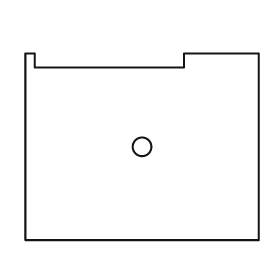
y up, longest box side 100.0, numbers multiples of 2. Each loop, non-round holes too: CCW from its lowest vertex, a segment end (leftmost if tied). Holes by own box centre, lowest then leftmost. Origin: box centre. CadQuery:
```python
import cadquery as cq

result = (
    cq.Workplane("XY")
    .moveTo(-50.0, -40.0)
    .lineTo(50.0, -40.0)
    .lineTo(50.0, 40.0)
    .lineTo(18.0, 40.0)
    .lineTo(18.0, 34.0)
    .lineTo(-46.0, 34.0)
    .lineTo(-46.0, 40.0)
    .lineTo(-50.0, 40.0)
    .close()
    .moveTo(0.0, 0.0)
    .circle(4.0)
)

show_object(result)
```